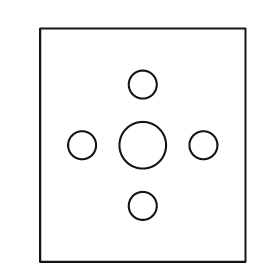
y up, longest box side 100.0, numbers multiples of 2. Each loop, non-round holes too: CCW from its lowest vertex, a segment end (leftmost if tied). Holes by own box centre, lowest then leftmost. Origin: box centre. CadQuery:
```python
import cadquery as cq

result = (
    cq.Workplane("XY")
    .moveTo(-44.0, -50.0)
    .lineTo(44.0, -50.0)
    .lineTo(44.0, 50.0)
    .lineTo(-44.0, 50.0)
    .close()
    .moveTo(0.0, -26.0)
    .circle(6.0)
    .moveTo(-26.0, 0.0)
    .circle(6.0)
    .moveTo(0.0, 0.0)
    .circle(10.0)
    .moveTo(26.0, 0.0)
    .circle(6.0)
    .moveTo(0.0, 26.0)
    .circle(6.0)
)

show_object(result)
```